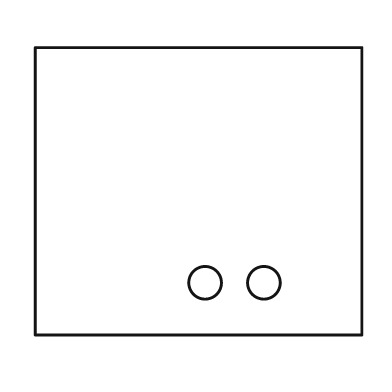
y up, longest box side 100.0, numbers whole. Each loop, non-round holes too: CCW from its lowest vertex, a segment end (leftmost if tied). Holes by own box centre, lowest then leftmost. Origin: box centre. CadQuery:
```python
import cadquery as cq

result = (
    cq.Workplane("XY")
    .moveTo(-50.0, -44.0)
    .lineTo(50.0, -44.0)
    .lineTo(50.0, 44.0)
    .lineTo(-50.0, 44.0)
    .close()
    .moveTo(2.0, -28.0)
    .circle(5.0)
    .moveTo(20.0, -28.0)
    .circle(5.0)
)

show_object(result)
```